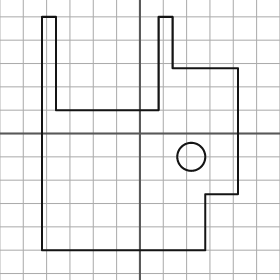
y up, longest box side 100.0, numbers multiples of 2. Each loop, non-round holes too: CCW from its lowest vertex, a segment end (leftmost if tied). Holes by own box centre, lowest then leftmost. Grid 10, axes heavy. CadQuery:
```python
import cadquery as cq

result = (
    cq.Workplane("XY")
    .moveTo(-42.0, -50.0)
    .lineTo(28.0, -50.0)
    .lineTo(28.0, -26.0)
    .lineTo(42.0, -26.0)
    .lineTo(42.0, 28.0)
    .lineTo(14.0, 28.0)
    .lineTo(14.0, 50.0)
    .lineTo(8.0, 50.0)
    .lineTo(8.0, 10.0)
    .lineTo(-36.0, 10.0)
    .lineTo(-36.0, 50.0)
    .lineTo(-42.0, 50.0)
    .close()
    .moveTo(22.0, -10.0)
    .circle(6.0)
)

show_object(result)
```